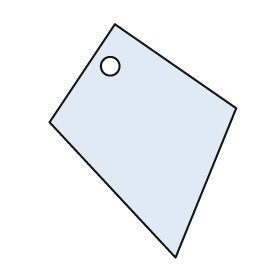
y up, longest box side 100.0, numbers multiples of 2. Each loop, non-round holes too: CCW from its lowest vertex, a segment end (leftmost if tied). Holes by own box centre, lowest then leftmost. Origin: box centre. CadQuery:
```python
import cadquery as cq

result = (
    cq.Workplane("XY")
    .moveTo(14.0, -50.0)
    .lineTo(40.0, 14.0)
    .lineTo(-12.0, 50.0)
    .lineTo(-40.0, 8.0)
    .close()
    .moveTo(-14.0, 32.0)
    .circle(4.0)
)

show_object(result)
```